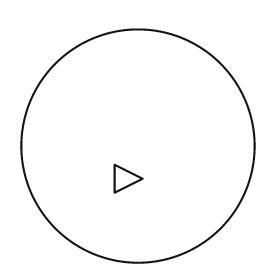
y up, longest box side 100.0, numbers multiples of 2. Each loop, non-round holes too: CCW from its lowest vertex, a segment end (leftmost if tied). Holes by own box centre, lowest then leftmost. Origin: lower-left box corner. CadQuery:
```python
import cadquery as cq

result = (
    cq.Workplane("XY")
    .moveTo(50.0, 50.0)
    .circle(50.0)
    .moveTo(40.0, 30.0)
    .lineTo(52.0, 36.0)
    .lineTo(40.0, 42.0)
    .close()
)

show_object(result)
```